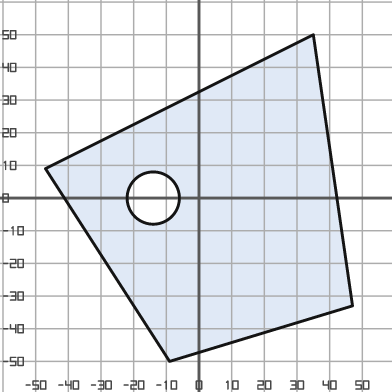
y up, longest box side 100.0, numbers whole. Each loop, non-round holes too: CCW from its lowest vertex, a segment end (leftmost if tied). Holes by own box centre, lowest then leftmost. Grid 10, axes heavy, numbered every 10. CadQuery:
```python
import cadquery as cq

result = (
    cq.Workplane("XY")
    .moveTo(-9.0, -50.0)
    .lineTo(47.0, -33.0)
    .lineTo(35.0, 50.0)
    .lineTo(-47.0, 9.0)
    .close()
    .moveTo(-14.0, 0.0)
    .circle(8.0)
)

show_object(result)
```